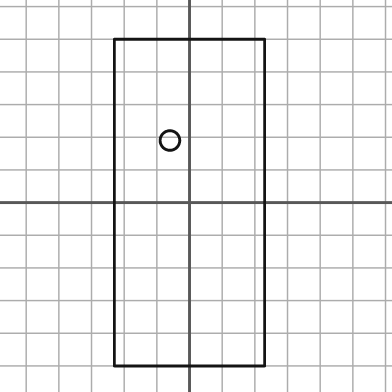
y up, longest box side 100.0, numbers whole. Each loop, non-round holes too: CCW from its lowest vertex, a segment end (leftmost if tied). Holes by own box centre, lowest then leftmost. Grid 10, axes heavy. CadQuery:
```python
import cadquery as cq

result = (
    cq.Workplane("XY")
    .moveTo(-23.0, -50.0)
    .lineTo(23.0, -50.0)
    .lineTo(23.0, 50.0)
    .lineTo(-23.0, 50.0)
    .close()
    .moveTo(-6.0, 19.0)
    .circle(3.0)
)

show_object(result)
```